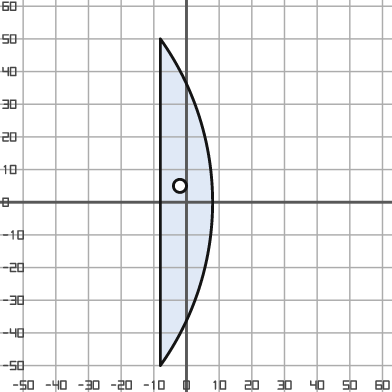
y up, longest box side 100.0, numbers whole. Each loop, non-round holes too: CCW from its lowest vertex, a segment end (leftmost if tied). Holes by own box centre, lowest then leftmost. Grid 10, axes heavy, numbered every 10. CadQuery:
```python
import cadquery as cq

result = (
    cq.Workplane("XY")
    .moveTo(-8.0, -50.0)
    .threePointArc((8.0, 0.0), (-8.0, 50.0))
    .close()
    .moveTo(-2.0, 5.0)
    .circle(2.0)
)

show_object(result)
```